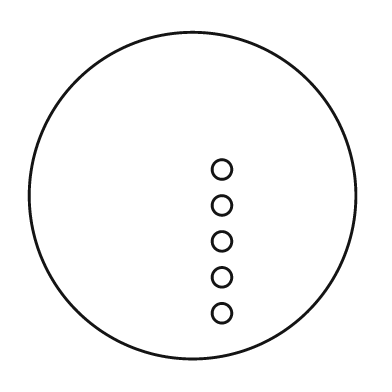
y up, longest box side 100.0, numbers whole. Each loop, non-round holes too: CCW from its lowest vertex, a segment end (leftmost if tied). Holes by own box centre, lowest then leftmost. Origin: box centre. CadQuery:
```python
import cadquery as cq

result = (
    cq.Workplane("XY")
    .moveTo(0.0, 0.0)
    .circle(50.0)
    .moveTo(9.0, -36.0)
    .circle(3.0)
    .moveTo(9.0, -25.0)
    .circle(3.0)
    .moveTo(9.0, -14.0)
    .circle(3.0)
    .moveTo(9.0, -3.0)
    .circle(3.0)
    .moveTo(9.0, 8.0)
    .circle(3.0)
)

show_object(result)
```